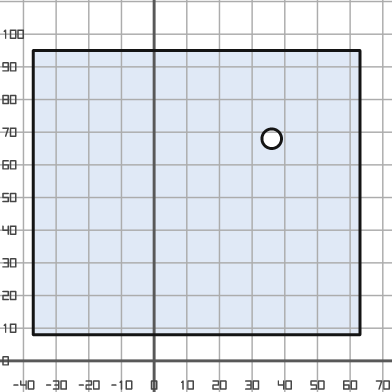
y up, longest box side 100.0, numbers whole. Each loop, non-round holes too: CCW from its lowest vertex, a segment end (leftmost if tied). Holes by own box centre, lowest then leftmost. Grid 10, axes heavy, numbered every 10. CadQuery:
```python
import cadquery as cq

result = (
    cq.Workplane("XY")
    .moveTo(-37.0, 8.0)
    .lineTo(63.0, 8.0)
    .lineTo(63.0, 95.0)
    .lineTo(-37.0, 95.0)
    .close()
    .moveTo(36.0, 68.0)
    .circle(3.0)
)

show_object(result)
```